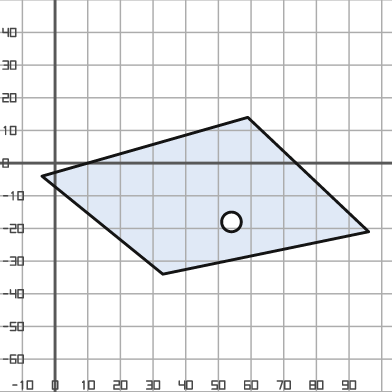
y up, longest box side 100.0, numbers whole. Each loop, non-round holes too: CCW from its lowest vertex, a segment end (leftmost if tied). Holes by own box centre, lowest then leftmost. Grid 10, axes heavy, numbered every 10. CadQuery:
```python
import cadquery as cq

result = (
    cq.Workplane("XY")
    .moveTo(33.0, -34.0)
    .lineTo(96.0, -21.0)
    .lineTo(59.0, 14.0)
    .lineTo(-4.0, -4.0)
    .close()
    .moveTo(54.0, -18.0)
    .circle(3.0)
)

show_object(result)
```